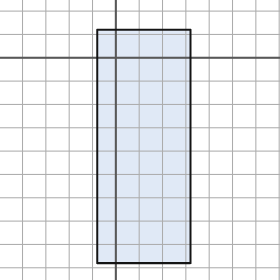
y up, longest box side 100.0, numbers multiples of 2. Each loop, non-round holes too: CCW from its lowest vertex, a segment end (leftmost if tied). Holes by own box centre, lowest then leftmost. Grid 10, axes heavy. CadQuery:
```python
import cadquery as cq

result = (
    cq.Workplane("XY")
    .moveTo(-8.0, -88.0)
    .lineTo(32.0, -88.0)
    .lineTo(32.0, 12.0)
    .lineTo(-8.0, 12.0)
    .close()
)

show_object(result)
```